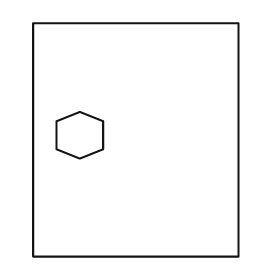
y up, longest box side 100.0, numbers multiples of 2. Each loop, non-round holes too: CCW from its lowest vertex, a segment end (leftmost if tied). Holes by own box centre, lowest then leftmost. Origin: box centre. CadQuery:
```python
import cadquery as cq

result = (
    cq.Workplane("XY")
    .moveTo(-44.0, -50.0)
    .lineTo(44.0, -50.0)
    .lineTo(44.0, 50.0)
    .lineTo(-44.0, 50.0)
    .close()
    .moveTo(-24.0, -8.0)
    .lineTo(-14.0, -4.0)
    .lineTo(-14.0, 8.0)
    .lineTo(-24.0, 12.0)
    .lineTo(-34.0, 8.0)
    .lineTo(-34.0, -4.0)
    .close()
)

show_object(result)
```